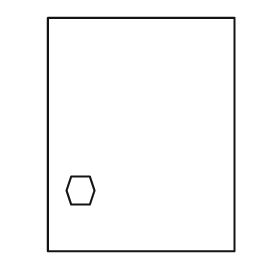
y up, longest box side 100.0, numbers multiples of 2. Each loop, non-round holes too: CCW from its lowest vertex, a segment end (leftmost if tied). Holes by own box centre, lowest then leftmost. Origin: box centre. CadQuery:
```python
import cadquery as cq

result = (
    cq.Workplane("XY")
    .moveTo(-40.0, -50.0)
    .lineTo(40.0, -50.0)
    .lineTo(40.0, 50.0)
    .lineTo(-40.0, 50.0)
    .close()
    .moveTo(-30.0, -30.0)
    .lineTo(-22.0, -30.0)
    .lineTo(-20.0, -24.0)
    .lineTo(-22.0, -18.0)
    .lineTo(-30.0, -18.0)
    .lineTo(-32.0, -24.0)
    .close()
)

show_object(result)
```